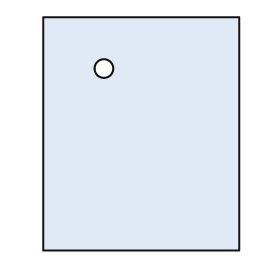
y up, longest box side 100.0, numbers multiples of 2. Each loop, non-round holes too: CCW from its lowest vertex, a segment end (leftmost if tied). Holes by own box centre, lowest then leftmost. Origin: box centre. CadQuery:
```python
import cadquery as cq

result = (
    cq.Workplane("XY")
    .moveTo(-42.0, -50.0)
    .lineTo(42.0, -50.0)
    .lineTo(42.0, 50.0)
    .lineTo(-42.0, 50.0)
    .close()
    .moveTo(-16.0, 28.0)
    .circle(4.0)
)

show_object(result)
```